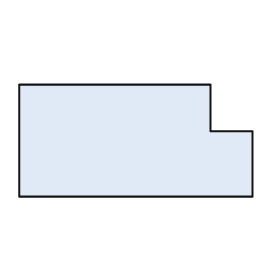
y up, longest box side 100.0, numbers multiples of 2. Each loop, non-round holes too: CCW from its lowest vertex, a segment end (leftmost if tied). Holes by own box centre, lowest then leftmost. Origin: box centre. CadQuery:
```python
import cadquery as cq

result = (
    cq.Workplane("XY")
    .moveTo(-50.0, -24.0)
    .lineTo(50.0, -24.0)
    .lineTo(50.0, 4.0)
    .lineTo(32.0, 4.0)
    .lineTo(32.0, 24.0)
    .lineTo(-50.0, 24.0)
    .close()
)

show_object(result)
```